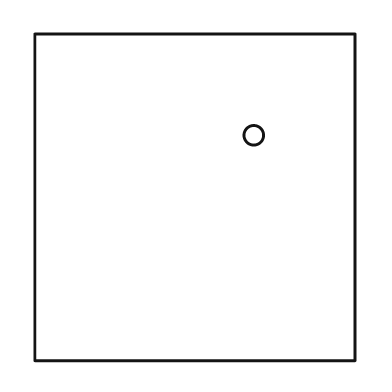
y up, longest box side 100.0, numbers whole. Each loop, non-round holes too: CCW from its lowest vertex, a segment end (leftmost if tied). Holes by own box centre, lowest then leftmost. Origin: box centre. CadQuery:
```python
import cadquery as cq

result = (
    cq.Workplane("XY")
    .moveTo(-49.0, -50.0)
    .lineTo(49.0, -50.0)
    .lineTo(49.0, 50.0)
    .lineTo(-49.0, 50.0)
    .close()
    .moveTo(18.0, 19.0)
    .circle(3.0)
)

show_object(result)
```